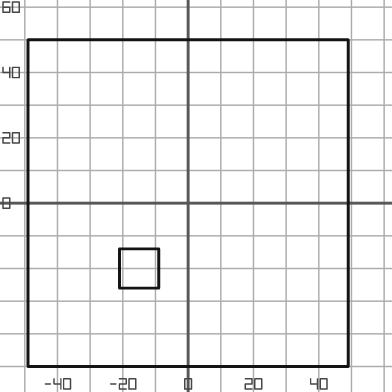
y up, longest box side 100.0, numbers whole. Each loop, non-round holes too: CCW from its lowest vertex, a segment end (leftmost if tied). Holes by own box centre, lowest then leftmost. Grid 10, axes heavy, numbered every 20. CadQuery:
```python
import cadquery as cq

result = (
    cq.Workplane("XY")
    .moveTo(-49.0, -50.0)
    .lineTo(49.0, -50.0)
    .lineTo(49.0, 50.0)
    .lineTo(-49.0, 50.0)
    .close()
    .moveTo(-21.0, -26.0)
    .lineTo(-9.0, -26.0)
    .lineTo(-9.0, -14.0)
    .lineTo(-21.0, -14.0)
    .close()
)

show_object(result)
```